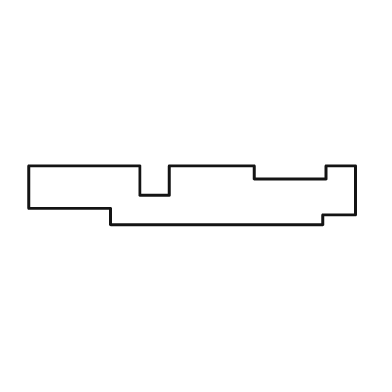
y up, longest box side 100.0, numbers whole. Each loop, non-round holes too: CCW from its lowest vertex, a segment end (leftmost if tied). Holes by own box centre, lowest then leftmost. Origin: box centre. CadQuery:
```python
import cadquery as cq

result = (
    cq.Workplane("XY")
    .moveTo(-25.0, -9.0)
    .lineTo(40.0, -9.0)
    .lineTo(40.0, -6.0)
    .lineTo(50.0, -6.0)
    .lineTo(50.0, 9.0)
    .lineTo(41.0, 9.0)
    .lineTo(41.0, 5.0)
    .lineTo(19.0, 5.0)
    .lineTo(19.0, 9.0)
    .lineTo(-7.0, 9.0)
    .lineTo(-7.0, 0.0)
    .lineTo(-16.0, 0.0)
    .lineTo(-16.0, 9.0)
    .lineTo(-50.0, 9.0)
    .lineTo(-50.0, -4.0)
    .lineTo(-25.0, -4.0)
    .close()
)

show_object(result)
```